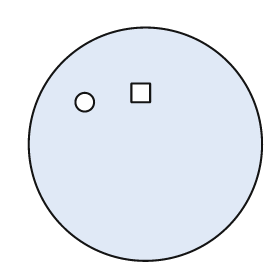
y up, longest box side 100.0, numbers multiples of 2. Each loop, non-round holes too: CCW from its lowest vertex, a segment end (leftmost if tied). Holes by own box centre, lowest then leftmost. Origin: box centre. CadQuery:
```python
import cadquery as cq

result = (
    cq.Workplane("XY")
    .moveTo(0.0, 0.0)
    .circle(50.0)
    .moveTo(-26.0, 18.0)
    .circle(4.0)
    .moveTo(-6.0, 18.0)
    .lineTo(2.0, 18.0)
    .lineTo(2.0, 26.0)
    .lineTo(-6.0, 26.0)
    .close()
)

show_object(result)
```